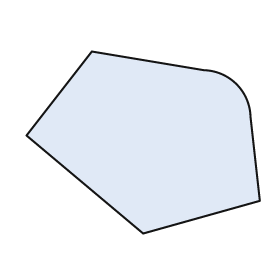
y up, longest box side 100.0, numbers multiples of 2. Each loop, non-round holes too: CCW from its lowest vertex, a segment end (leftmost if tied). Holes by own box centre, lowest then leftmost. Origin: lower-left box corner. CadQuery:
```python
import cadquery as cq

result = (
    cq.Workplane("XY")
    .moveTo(50.0, 0.0)
    .lineTo(100.0, 14.0)
    .lineTo(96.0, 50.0)
    .threePointArc((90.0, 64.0), (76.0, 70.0))
    .lineTo(28.0, 78.0)
    .lineTo(0.0, 42.0)
    .close()
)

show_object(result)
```